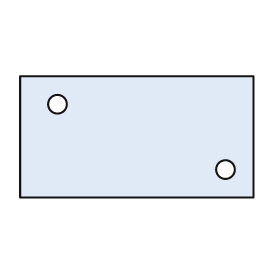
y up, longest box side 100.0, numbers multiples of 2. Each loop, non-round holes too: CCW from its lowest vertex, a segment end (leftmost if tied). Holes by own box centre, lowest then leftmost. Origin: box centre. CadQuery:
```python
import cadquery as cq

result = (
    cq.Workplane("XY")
    .moveTo(-50.0, -26.0)
    .lineTo(50.0, -26.0)
    .lineTo(50.0, 26.0)
    .lineTo(-50.0, 26.0)
    .close()
    .moveTo(38.0, -14.0)
    .circle(4.0)
    .moveTo(-34.0, 14.0)
    .circle(4.0)
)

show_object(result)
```